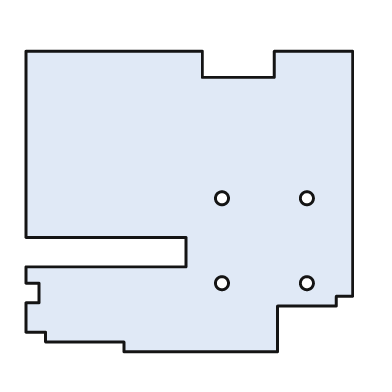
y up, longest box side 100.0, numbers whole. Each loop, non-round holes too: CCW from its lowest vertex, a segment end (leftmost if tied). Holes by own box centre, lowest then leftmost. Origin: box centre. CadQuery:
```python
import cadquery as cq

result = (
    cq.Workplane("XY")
    .moveTo(-20.0, -46.0)
    .lineTo(27.0, -46.0)
    .lineTo(27.0, -32.0)
    .lineTo(45.0, -32.0)
    .lineTo(45.0, -29.0)
    .lineTo(50.0, -29.0)
    .lineTo(50.0, 46.0)
    .lineTo(26.0, 46.0)
    .lineTo(26.0, 38.0)
    .lineTo(4.0, 38.0)
    .lineTo(4.0, 46.0)
    .lineTo(-50.0, 46.0)
    .lineTo(-50.0, -11.0)
    .lineTo(-1.0, -11.0)
    .lineTo(-1.0, -20.0)
    .lineTo(-50.0, -20.0)
    .lineTo(-50.0, -25.0)
    .lineTo(-46.0, -25.0)
    .lineTo(-46.0, -31.0)
    .lineTo(-50.0, -31.0)
    .lineTo(-50.0, -40.0)
    .lineTo(-44.0, -40.0)
    .lineTo(-44.0, -43.0)
    .lineTo(-20.0, -43.0)
    .close()
    .moveTo(10.0, -25.0)
    .circle(2.0)
    .moveTo(36.0, -25.0)
    .circle(2.0)
    .moveTo(10.0, 1.0)
    .circle(2.0)
    .moveTo(36.0, 1.0)
    .circle(2.0)
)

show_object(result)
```